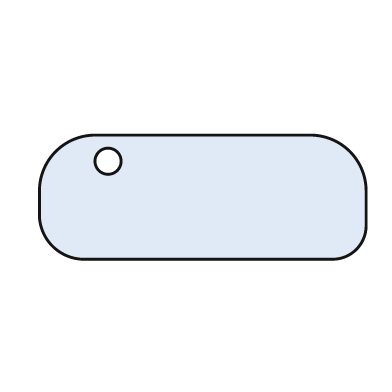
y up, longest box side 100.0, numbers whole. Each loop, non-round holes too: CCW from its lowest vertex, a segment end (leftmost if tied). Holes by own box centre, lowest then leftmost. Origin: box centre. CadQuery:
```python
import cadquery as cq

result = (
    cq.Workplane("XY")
    .moveTo(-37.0, -19.0)
    .lineTo(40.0, -19.0)
    .threePointArc((47.0, -16.0), (50.0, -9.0))
    .lineTo(50.0, 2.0)
    .threePointArc((45.0, 14.0), (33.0, 19.0))
    .lineTo(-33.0, 19.0)
    .threePointArc((-45.0, 14.0), (-50.0, 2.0))
    .lineTo(-50.0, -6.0)
    .threePointArc((-46.0, -15.0), (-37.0, -19.0))
    .close()
    .moveTo(-29.0, 11.0)
    .circle(4.0)
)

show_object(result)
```